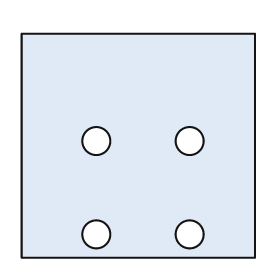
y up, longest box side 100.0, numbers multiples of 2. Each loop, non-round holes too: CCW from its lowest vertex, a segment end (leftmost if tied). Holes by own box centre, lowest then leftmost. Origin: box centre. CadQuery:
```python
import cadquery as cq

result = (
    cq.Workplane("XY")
    .moveTo(-50.0, -48.0)
    .lineTo(50.0, -48.0)
    .lineTo(50.0, 48.0)
    .lineTo(-50.0, 48.0)
    .close()
    .moveTo(-18.0, -38.0)
    .circle(6.0)
    .moveTo(22.0, -38.0)
    .circle(6.0)
    .moveTo(-18.0, 2.0)
    .circle(6.0)
    .moveTo(22.0, 2.0)
    .circle(6.0)
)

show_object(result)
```